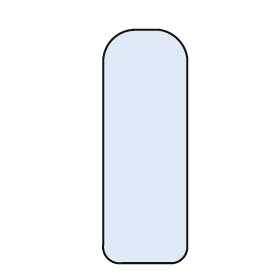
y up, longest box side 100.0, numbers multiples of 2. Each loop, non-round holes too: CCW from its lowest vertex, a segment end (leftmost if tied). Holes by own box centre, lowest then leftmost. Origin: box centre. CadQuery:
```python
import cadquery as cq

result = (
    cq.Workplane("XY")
    .moveTo(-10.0, -50.0)
    .lineTo(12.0, -50.0)
    .threePointArc((16.0, -48.0), (18.0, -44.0))
    .lineTo(18.0, 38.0)
    .threePointArc((14.0, 46.0), (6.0, 50.0))
    .lineTo(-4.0, 50.0)
    .threePointArc((-14.0, 46.0), (-18.0, 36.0))
    .lineTo(-18.0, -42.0)
    .threePointArc((-16.0, -48.0), (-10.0, -50.0))
    .close()
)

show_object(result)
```